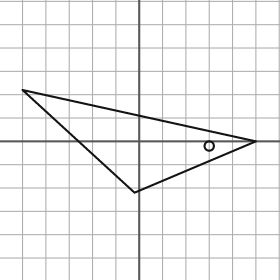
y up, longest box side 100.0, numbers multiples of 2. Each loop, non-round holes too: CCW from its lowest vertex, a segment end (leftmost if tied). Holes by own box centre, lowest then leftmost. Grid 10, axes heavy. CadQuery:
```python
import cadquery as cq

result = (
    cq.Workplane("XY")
    .moveTo(-2.0, -22.0)
    .lineTo(50.0, 0.0)
    .lineTo(-50.0, 22.0)
    .close()
    .moveTo(30.0, -2.0)
    .circle(2.0)
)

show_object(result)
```